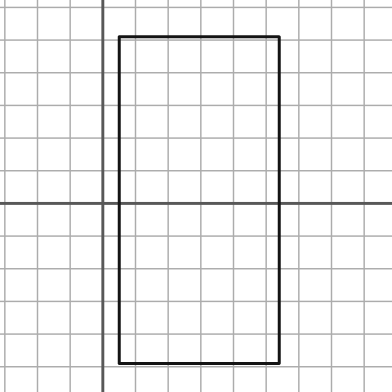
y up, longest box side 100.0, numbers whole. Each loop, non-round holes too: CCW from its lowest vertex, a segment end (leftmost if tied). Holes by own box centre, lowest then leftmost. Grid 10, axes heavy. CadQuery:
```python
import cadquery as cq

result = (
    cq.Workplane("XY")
    .moveTo(5.0, -49.0)
    .lineTo(54.0, -49.0)
    .lineTo(54.0, 51.0)
    .lineTo(5.0, 51.0)
    .close()
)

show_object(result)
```